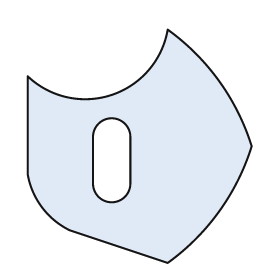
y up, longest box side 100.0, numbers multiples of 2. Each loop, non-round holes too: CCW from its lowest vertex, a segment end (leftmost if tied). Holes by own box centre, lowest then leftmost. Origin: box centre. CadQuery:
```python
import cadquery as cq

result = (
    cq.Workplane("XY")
    .moveTo(12.0, -50.0)
    .threePointArc((34.0, -28.0), (48.0, 0.0))
    .threePointArc((34.0, 28.0), (12.0, 50.0))
    .threePointArc((-12.0, 22.0), (-48.0, 30.0))
    .lineTo(-48.0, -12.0)
    .threePointArc((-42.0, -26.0), (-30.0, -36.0))
    .close()
    .moveTo(-20.0, -16.0)
    .threePointArc((-12.0, -24.0), (-4.0, -16.0))
    .lineTo(-4.0, 4.0)
    .threePointArc((-12.0, 12.0), (-20.0, 4.0))
    .close()
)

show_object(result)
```